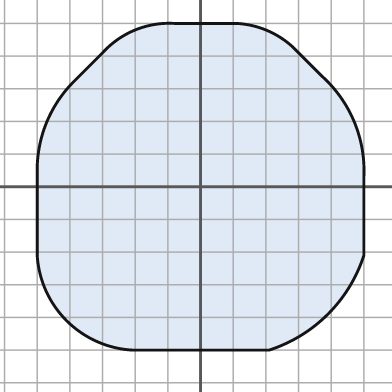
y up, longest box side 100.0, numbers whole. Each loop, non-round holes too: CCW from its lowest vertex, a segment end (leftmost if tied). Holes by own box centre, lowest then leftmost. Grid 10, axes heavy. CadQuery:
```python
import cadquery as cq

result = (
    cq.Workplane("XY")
    .moveTo(-21.0, -50.0)
    .lineTo(21.0, -50.0)
    .threePointArc((39.0, -39.0), (50.0, -21.0))
    .lineTo(50.0, 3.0)
    .threePointArc((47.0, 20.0), (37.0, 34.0))
    .lineTo(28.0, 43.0)
    .threePointArc((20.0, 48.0), (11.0, 50.0))
    .lineTo(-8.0, 50.0)
    .threePointArc((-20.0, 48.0), (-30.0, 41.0))
    .lineTo(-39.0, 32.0)
    .threePointArc((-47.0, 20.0), (-50.0, 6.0))
    .lineTo(-50.0, -21.0)
    .threePointArc((-41.0, -41.0), (-21.0, -50.0))
    .close()
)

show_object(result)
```